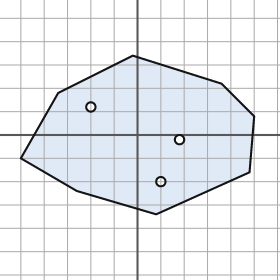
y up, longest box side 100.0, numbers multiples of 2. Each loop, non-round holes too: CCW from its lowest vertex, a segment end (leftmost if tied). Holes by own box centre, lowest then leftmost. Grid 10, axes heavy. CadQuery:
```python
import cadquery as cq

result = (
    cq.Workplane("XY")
    .moveTo(8.0, -34.0)
    .lineTo(48.0, -16.0)
    .lineTo(50.0, 8.0)
    .lineTo(36.0, 22.0)
    .lineTo(-2.0, 34.0)
    .lineTo(-34.0, 18.0)
    .lineTo(-50.0, -10.0)
    .lineTo(-26.0, -24.0)
    .close()
    .moveTo(10.0, -20.0)
    .circle(2.0)
    .moveTo(18.0, -2.0)
    .circle(2.0)
    .moveTo(-20.0, 12.0)
    .circle(2.0)
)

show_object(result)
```